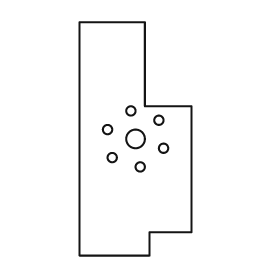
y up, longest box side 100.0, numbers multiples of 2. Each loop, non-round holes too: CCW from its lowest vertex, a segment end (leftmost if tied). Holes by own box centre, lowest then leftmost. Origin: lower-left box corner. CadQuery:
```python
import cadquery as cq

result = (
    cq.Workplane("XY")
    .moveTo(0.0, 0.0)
    .lineTo(30.0, 0.0)
    .lineTo(30.0, 10.0)
    .lineTo(48.0, 10.0)
    .lineTo(48.0, 64.0)
    .lineTo(28.0, 64.0)
    .lineTo(28.0, 100.0)
    .lineTo(0.0, 100.0)
    .close()
    .moveTo(26.0, 38.0)
    .circle(2.0)
    .moveTo(14.0, 42.0)
    .circle(2.0)
    .moveTo(36.0, 46.0)
    .circle(2.0)
    .moveTo(24.0, 50.0)
    .circle(4.0)
    .moveTo(12.0, 54.0)
    .circle(2.0)
    .moveTo(34.0, 58.0)
    .circle(2.0)
    .moveTo(22.0, 62.0)
    .circle(2.0)
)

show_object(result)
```